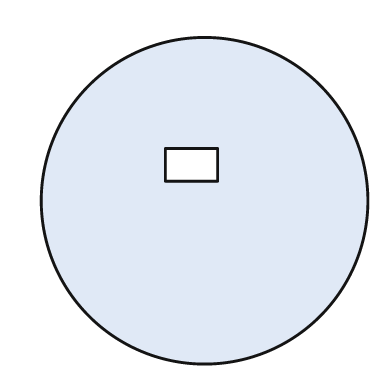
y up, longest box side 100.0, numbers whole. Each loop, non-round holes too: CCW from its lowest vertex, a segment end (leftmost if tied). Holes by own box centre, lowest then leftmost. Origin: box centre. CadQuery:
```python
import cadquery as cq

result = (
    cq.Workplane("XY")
    .moveTo(0.0, 0.0)
    .circle(50.0)
    .moveTo(-12.0, 6.0)
    .lineTo(4.0, 6.0)
    .lineTo(4.0, 16.0)
    .lineTo(-12.0, 16.0)
    .close()
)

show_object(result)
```